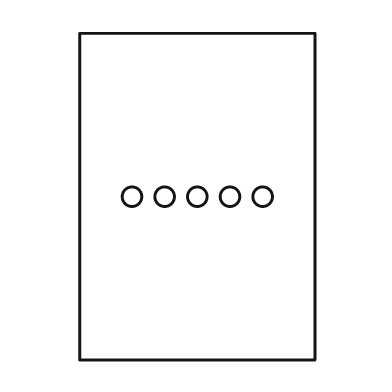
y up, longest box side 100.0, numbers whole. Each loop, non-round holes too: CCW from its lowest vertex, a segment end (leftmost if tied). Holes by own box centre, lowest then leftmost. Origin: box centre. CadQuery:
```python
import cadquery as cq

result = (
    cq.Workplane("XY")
    .moveTo(-36.0, -50.0)
    .lineTo(36.0, -50.0)
    .lineTo(36.0, 50.0)
    .lineTo(-36.0, 50.0)
    .close()
    .moveTo(-20.0, 0.0)
    .circle(3.0)
    .moveTo(-10.0, 0.0)
    .circle(3.0)
    .moveTo(0.0, 0.0)
    .circle(3.0)
    .moveTo(10.0, 0.0)
    .circle(3.0)
    .moveTo(20.0, 0.0)
    .circle(3.0)
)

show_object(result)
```